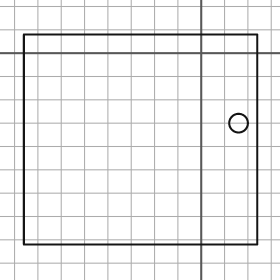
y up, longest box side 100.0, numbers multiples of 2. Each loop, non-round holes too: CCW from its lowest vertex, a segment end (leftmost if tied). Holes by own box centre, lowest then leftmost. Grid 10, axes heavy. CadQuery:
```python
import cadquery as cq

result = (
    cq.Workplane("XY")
    .moveTo(-76.0, -82.0)
    .lineTo(24.0, -82.0)
    .lineTo(24.0, 8.0)
    .lineTo(-76.0, 8.0)
    .close()
    .moveTo(16.0, -30.0)
    .circle(4.0)
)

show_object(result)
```